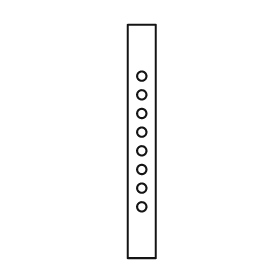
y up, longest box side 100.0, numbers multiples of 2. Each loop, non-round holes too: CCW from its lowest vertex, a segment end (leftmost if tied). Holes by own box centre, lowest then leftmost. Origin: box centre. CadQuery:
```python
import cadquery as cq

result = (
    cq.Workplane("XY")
    .moveTo(-6.0, -50.0)
    .lineTo(6.0, -50.0)
    .lineTo(6.0, 50.0)
    .lineTo(-6.0, 50.0)
    .close()
    .moveTo(0.0, -28.0)
    .circle(2.0)
    .moveTo(0.0, -20.0)
    .circle(2.0)
    .moveTo(0.0, -12.0)
    .circle(2.0)
    .moveTo(0.0, -4.0)
    .circle(2.0)
    .moveTo(0.0, 4.0)
    .circle(2.0)
    .moveTo(0.0, 12.0)
    .circle(2.0)
    .moveTo(0.0, 20.0)
    .circle(2.0)
    .moveTo(0.0, 28.0)
    .circle(2.0)
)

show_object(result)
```